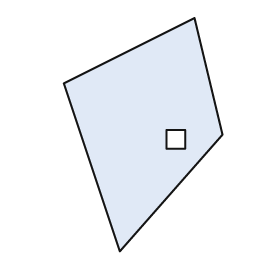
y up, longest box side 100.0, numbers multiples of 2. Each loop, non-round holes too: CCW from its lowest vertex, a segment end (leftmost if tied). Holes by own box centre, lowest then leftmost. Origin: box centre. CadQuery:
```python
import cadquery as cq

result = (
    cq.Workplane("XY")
    .moveTo(-10.0, -50.0)
    .lineTo(34.0, 0.0)
    .lineTo(22.0, 50.0)
    .lineTo(-34.0, 22.0)
    .close()
    .moveTo(10.0, -6.0)
    .lineTo(18.0, -6.0)
    .lineTo(18.0, 2.0)
    .lineTo(10.0, 2.0)
    .close()
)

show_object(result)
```